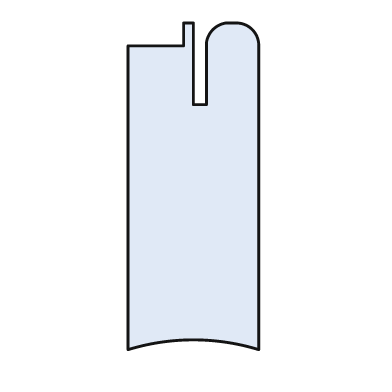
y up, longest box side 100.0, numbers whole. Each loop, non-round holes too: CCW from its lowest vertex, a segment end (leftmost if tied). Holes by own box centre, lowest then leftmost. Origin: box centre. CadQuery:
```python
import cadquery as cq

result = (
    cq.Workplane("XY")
    .moveTo(-20.0, -50.0)
    .threePointArc((0.0, -47.0), (20.0, -50.0))
    .lineTo(20.0, 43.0)
    .threePointArc((18.0, 48.0), (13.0, 50.0))
    .lineTo(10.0, 50.0)
    .threePointArc((6.0, 48.0), (4.0, 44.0))
    .lineTo(4.0, 25.0)
    .lineTo(0.0, 25.0)
    .lineTo(0.0, 50.0)
    .lineTo(-3.0, 50.0)
    .lineTo(-3.0, 43.0)
    .lineTo(-20.0, 43.0)
    .close()
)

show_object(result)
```